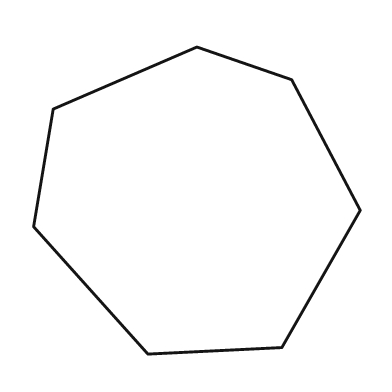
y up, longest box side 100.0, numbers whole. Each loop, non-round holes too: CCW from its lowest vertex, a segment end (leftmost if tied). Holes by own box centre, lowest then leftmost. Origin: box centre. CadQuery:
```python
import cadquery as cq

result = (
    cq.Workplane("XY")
    .moveTo(-15.0, -47.0)
    .lineTo(26.0, -45.0)
    .lineTo(50.0, -3.0)
    .lineTo(29.0, 37.0)
    .lineTo(0.0, 47.0)
    .lineTo(-44.0, 28.0)
    .lineTo(-50.0, -8.0)
    .close()
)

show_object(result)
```